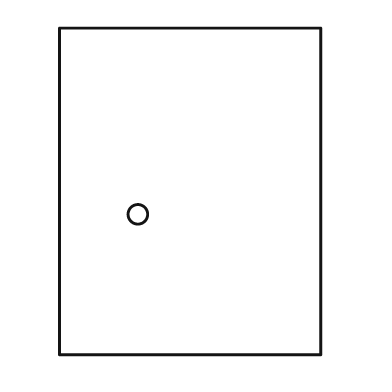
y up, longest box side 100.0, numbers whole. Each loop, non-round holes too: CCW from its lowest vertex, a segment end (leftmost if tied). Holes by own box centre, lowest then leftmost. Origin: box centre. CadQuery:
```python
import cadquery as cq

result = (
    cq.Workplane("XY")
    .moveTo(-40.0, -50.0)
    .lineTo(40.0, -50.0)
    .lineTo(40.0, 50.0)
    .lineTo(-40.0, 50.0)
    .close()
    .moveTo(-16.0, -7.0)
    .circle(3.0)
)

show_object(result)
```